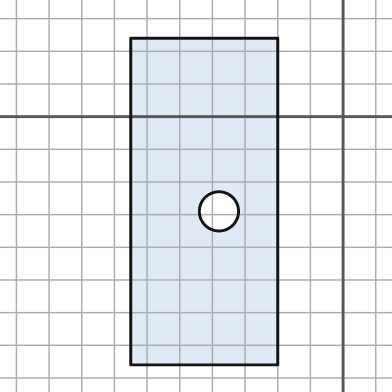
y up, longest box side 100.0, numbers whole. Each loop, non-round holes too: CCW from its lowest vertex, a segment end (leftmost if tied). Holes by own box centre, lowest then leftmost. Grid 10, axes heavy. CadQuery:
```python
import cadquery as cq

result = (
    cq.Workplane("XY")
    .moveTo(-65.0, -76.0)
    .lineTo(-20.0, -76.0)
    .lineTo(-20.0, 24.0)
    .lineTo(-65.0, 24.0)
    .close()
    .moveTo(-38.0, -29.0)
    .circle(6.0)
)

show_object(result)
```